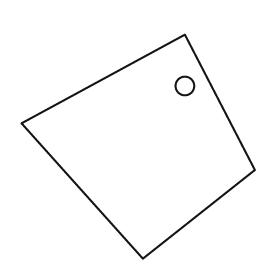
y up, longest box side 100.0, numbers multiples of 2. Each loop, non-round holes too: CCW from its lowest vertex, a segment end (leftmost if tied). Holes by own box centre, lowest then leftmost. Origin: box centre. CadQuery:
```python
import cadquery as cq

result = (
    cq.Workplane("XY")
    .moveTo(2.0, -48.0)
    .lineTo(50.0, -10.0)
    .lineTo(20.0, 48.0)
    .lineTo(-50.0, 10.0)
    .close()
    .moveTo(20.0, 26.0)
    .circle(4.0)
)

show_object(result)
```